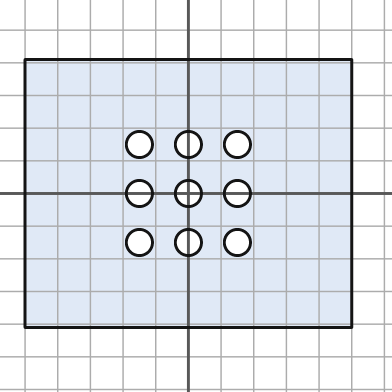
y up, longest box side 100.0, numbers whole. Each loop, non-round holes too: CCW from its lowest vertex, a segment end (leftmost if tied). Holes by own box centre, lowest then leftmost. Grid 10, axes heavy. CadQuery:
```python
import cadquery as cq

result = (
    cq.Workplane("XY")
    .moveTo(-50.0, -41.0)
    .lineTo(50.0, -41.0)
    .lineTo(50.0, 41.0)
    .lineTo(-50.0, 41.0)
    .close()
    .moveTo(-15.0, -15.0)
    .circle(4.0)
    .moveTo(0.0, -15.0)
    .circle(4.0)
    .moveTo(15.0, -15.0)
    .circle(4.0)
    .moveTo(-15.0, 0.0)
    .circle(4.0)
    .moveTo(0.0, 0.0)
    .circle(4.0)
    .moveTo(15.0, 0.0)
    .circle(4.0)
    .moveTo(-15.0, 15.0)
    .circle(4.0)
    .moveTo(0.0, 15.0)
    .circle(4.0)
    .moveTo(15.0, 15.0)
    .circle(4.0)
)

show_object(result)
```